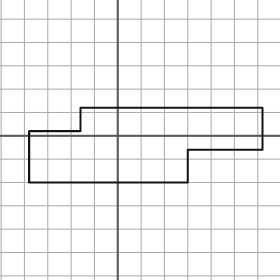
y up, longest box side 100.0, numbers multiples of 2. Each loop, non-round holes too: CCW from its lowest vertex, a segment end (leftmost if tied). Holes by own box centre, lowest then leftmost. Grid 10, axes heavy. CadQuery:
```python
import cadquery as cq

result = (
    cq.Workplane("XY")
    .moveTo(-38.0, -20.0)
    .lineTo(30.0, -20.0)
    .lineTo(30.0, -6.0)
    .lineTo(62.0, -6.0)
    .lineTo(62.0, 12.0)
    .lineTo(-16.0, 12.0)
    .lineTo(-16.0, 2.0)
    .lineTo(-38.0, 2.0)
    .close()
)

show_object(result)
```